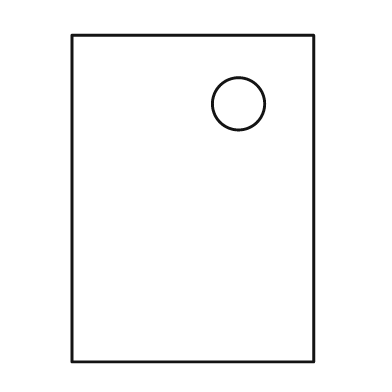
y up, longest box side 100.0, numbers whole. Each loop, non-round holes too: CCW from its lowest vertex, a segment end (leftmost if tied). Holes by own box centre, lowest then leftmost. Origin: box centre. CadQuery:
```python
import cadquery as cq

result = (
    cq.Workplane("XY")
    .moveTo(-37.0, -50.0)
    .lineTo(37.0, -50.0)
    .lineTo(37.0, 50.0)
    .lineTo(-37.0, 50.0)
    .close()
    .moveTo(14.0, 29.0)
    .circle(8.0)
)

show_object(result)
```